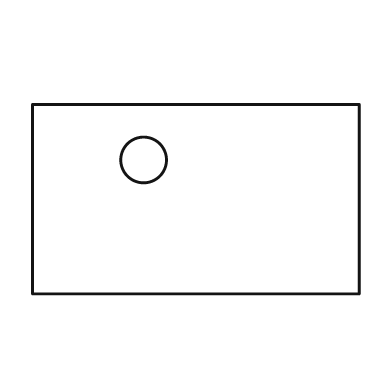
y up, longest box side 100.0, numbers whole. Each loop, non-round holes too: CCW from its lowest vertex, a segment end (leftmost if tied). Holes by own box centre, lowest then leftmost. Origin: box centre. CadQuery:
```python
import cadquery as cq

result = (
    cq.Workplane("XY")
    .moveTo(-50.0, -29.0)
    .lineTo(50.0, -29.0)
    .lineTo(50.0, 29.0)
    .lineTo(-50.0, 29.0)
    .close()
    .moveTo(-16.0, 12.0)
    .circle(7.0)
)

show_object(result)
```